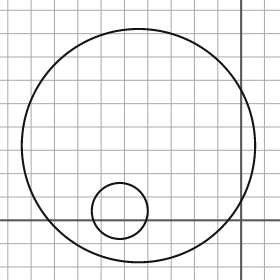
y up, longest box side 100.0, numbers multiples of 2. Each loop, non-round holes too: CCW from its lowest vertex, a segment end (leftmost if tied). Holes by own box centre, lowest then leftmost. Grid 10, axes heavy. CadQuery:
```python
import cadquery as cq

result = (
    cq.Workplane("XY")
    .moveTo(-44.0, 32.0)
    .circle(50.0)
    .moveTo(-52.0, 4.0)
    .circle(12.0)
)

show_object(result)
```